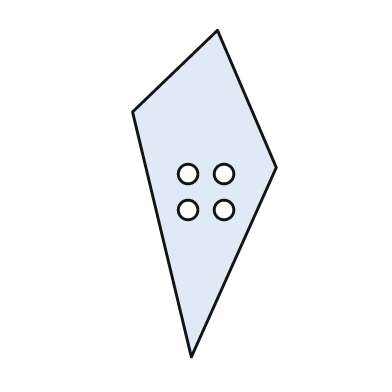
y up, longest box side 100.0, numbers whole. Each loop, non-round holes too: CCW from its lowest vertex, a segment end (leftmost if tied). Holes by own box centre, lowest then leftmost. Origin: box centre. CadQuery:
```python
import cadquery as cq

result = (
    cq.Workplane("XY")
    .moveTo(-4.0, -50.0)
    .lineTo(22.0, 8.0)
    .lineTo(4.0, 50.0)
    .lineTo(-22.0, 25.0)
    .close()
    .moveTo(-5.0, -5.0)
    .circle(3.0)
    .moveTo(6.0, -5.0)
    .circle(3.0)
    .moveTo(-5.0, 6.0)
    .circle(3.0)
    .moveTo(6.0, 6.0)
    .circle(3.0)
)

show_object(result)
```